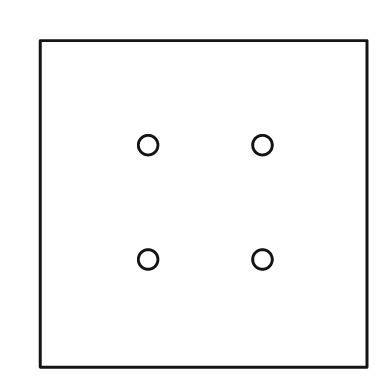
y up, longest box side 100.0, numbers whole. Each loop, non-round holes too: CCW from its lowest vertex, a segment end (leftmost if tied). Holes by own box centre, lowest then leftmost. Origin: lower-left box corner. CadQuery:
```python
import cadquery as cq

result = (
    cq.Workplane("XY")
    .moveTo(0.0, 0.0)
    .lineTo(100.0, 0.0)
    .lineTo(100.0, 100.0)
    .lineTo(0.0, 100.0)
    .close()
    .moveTo(33.0, 33.0)
    .circle(3.0)
    .moveTo(68.0, 33.0)
    .circle(3.0)
    .moveTo(33.0, 68.0)
    .circle(3.0)
    .moveTo(68.0, 68.0)
    .circle(3.0)
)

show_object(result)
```